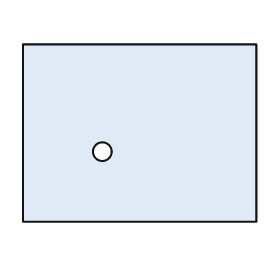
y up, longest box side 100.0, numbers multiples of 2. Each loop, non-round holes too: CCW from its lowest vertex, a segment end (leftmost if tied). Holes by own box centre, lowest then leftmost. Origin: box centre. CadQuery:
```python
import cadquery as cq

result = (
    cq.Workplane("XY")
    .moveTo(-50.0, -38.0)
    .lineTo(50.0, -38.0)
    .lineTo(50.0, 38.0)
    .lineTo(-50.0, 38.0)
    .close()
    .moveTo(-16.0, -8.0)
    .circle(4.0)
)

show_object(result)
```